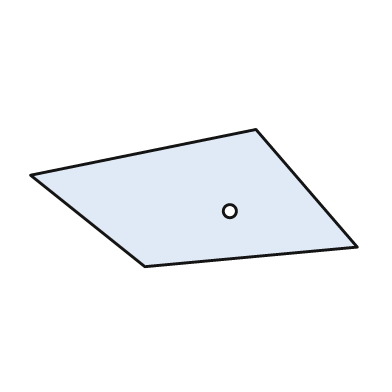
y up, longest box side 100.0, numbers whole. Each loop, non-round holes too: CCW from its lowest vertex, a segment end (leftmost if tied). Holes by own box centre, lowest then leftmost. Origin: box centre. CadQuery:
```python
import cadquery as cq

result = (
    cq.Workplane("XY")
    .moveTo(-15.0, -21.0)
    .lineTo(50.0, -15.0)
    .lineTo(19.0, 21.0)
    .lineTo(-50.0, 7.0)
    .close()
    .moveTo(11.0, -4.0)
    .circle(2.0)
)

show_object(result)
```